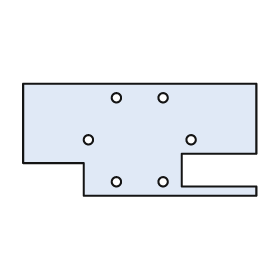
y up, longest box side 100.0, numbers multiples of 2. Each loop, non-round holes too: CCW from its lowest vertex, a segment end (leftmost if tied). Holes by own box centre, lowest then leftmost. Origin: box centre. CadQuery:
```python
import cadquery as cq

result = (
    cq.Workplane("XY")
    .moveTo(-24.0, -24.0)
    .lineTo(50.0, -24.0)
    .lineTo(50.0, -20.0)
    .lineTo(18.0, -20.0)
    .lineTo(18.0, -6.0)
    .lineTo(50.0, -6.0)
    .lineTo(50.0, 24.0)
    .lineTo(-50.0, 24.0)
    .lineTo(-50.0, -10.0)
    .lineTo(-24.0, -10.0)
    .close()
    .moveTo(-10.0, -18.0)
    .circle(2.0)
    .moveTo(10.0, -18.0)
    .circle(2.0)
    .moveTo(-22.0, 0.0)
    .circle(2.0)
    .moveTo(22.0, 0.0)
    .circle(2.0)
    .moveTo(-10.0, 18.0)
    .circle(2.0)
    .moveTo(10.0, 18.0)
    .circle(2.0)
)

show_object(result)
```